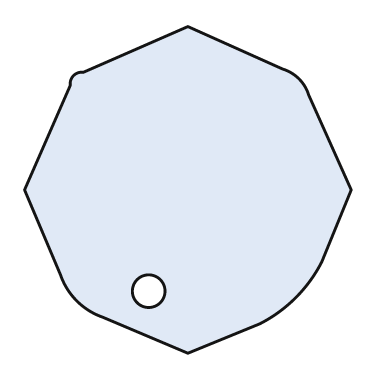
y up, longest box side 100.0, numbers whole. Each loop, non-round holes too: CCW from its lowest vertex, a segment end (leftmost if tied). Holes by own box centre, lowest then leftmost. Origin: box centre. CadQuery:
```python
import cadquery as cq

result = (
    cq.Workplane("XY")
    .moveTo(0.0, -50.0)
    .lineTo(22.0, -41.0)
    .threePointArc((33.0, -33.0), (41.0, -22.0))
    .lineTo(50.0, 0.0)
    .lineTo(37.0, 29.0)
    .threePointArc((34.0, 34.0), (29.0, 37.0))
    .lineTo(0.0, 50.0)
    .lineTo(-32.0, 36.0)
    .threePointArc((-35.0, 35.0), (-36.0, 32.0))
    .lineTo(-50.0, 0.0)
    .lineTo(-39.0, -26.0)
    .threePointArc((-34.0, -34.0), (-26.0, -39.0))
    .close()
    .moveTo(-12.0, -31.0)
    .circle(5.0)
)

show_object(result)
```